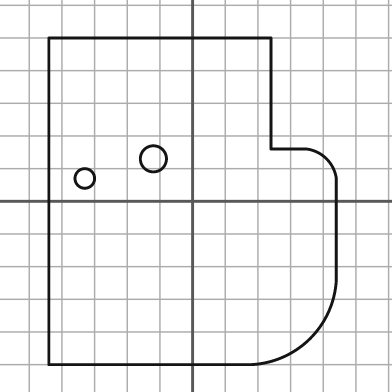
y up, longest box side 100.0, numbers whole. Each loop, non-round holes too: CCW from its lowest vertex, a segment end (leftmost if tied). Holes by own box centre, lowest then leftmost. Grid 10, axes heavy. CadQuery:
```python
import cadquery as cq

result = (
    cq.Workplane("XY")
    .moveTo(-44.0, -50.0)
    .lineTo(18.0, -50.0)
    .threePointArc((36.0, -42.0), (44.0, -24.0))
    .lineTo(44.0, 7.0)
    .threePointArc((41.0, 13.0), (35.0, 16.0))
    .lineTo(24.0, 16.0)
    .lineTo(24.0, 50.0)
    .lineTo(-44.0, 50.0)
    .close()
    .moveTo(-33.0, 7.0)
    .circle(3.0)
    .moveTo(-12.0, 13.0)
    .circle(4.0)
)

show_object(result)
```